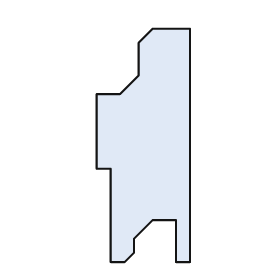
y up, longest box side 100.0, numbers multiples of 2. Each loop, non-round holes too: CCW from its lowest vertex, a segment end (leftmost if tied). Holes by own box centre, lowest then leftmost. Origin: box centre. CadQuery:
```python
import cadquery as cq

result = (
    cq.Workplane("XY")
    .moveTo(-14.0, -50.0)
    .lineTo(-8.0, -50.0)
    .lineTo(-4.0, -46.0)
    .lineTo(-4.0, -40.0)
    .lineTo(4.0, -32.0)
    .lineTo(14.0, -32.0)
    .lineTo(14.0, -50.0)
    .lineTo(20.0, -50.0)
    .lineTo(20.0, 50.0)
    .lineTo(4.0, 50.0)
    .lineTo(-2.0, 44.0)
    .lineTo(-2.0, 30.0)
    .lineTo(-10.0, 22.0)
    .lineTo(-20.0, 22.0)
    .lineTo(-20.0, -10.0)
    .lineTo(-14.0, -10.0)
    .close()
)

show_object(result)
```